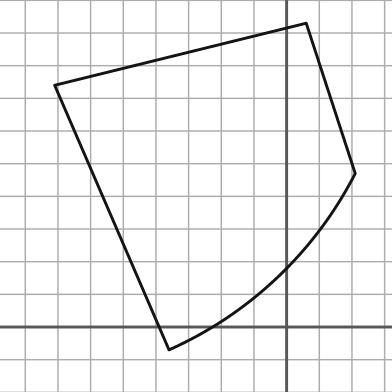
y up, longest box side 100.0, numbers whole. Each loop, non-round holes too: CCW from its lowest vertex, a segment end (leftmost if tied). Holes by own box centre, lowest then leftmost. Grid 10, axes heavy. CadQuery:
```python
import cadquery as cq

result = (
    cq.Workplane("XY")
    .moveTo(-36.0, -7.0)
    .threePointArc((-3.0, 15.0), (21.0, 47.0))
    .lineTo(6.0, 93.0)
    .lineTo(-71.0, 74.0)
    .close()
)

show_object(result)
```